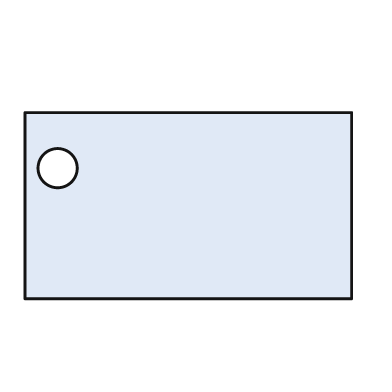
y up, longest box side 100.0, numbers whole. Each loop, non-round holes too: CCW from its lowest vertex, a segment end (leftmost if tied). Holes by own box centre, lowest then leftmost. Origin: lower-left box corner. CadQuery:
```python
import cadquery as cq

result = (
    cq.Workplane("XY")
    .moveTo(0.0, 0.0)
    .lineTo(100.0, 0.0)
    .lineTo(100.0, 57.0)
    .lineTo(0.0, 57.0)
    .close()
    .moveTo(10.0, 40.0)
    .circle(6.0)
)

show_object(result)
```